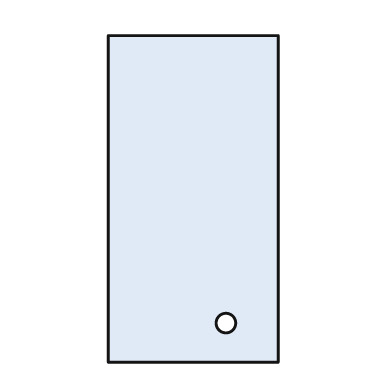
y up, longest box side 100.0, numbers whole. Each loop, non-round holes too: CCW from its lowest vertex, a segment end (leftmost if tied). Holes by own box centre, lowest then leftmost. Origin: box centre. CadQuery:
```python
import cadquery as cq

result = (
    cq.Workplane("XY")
    .moveTo(-26.0, -50.0)
    .lineTo(26.0, -50.0)
    .lineTo(26.0, 50.0)
    .lineTo(-26.0, 50.0)
    .close()
    .moveTo(10.0, -38.0)
    .circle(3.0)
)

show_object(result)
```